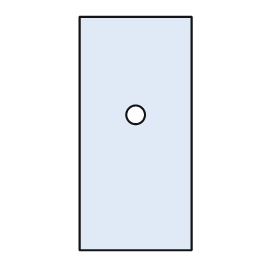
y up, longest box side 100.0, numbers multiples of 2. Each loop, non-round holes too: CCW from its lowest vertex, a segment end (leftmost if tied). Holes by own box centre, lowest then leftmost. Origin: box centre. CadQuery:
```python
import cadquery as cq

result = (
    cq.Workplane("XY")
    .moveTo(-24.0, -50.0)
    .lineTo(24.0, -50.0)
    .lineTo(24.0, 50.0)
    .lineTo(-24.0, 50.0)
    .close()
    .moveTo(0.0, 8.0)
    .circle(4.0)
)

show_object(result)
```